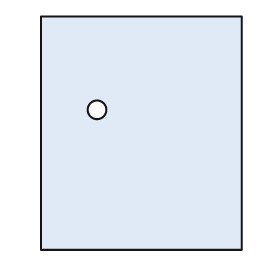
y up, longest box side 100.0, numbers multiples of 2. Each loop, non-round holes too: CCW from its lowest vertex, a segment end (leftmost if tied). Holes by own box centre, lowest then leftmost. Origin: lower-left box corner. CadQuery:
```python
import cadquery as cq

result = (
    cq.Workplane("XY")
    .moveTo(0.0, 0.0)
    .lineTo(86.0, 0.0)
    .lineTo(86.0, 100.0)
    .lineTo(0.0, 100.0)
    .close()
    .moveTo(24.0, 60.0)
    .circle(4.0)
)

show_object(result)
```